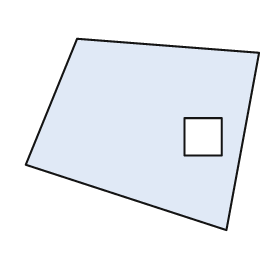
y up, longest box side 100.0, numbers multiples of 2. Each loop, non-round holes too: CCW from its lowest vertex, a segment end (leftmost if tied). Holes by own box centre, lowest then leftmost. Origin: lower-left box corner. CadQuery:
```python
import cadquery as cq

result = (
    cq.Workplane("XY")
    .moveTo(86.0, 0.0)
    .lineTo(100.0, 76.0)
    .lineTo(22.0, 82.0)
    .lineTo(0.0, 28.0)
    .close()
    .moveTo(68.0, 32.0)
    .lineTo(84.0, 32.0)
    .lineTo(84.0, 48.0)
    .lineTo(68.0, 48.0)
    .close()
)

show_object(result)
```